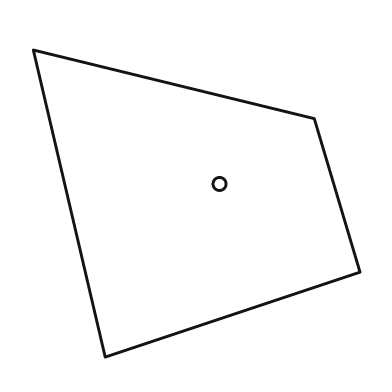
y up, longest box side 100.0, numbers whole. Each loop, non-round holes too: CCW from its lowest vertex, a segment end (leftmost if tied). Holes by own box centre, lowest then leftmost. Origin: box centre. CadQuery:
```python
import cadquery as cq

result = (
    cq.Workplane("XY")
    .moveTo(-28.0, -47.0)
    .lineTo(50.0, -21.0)
    .lineTo(36.0, 26.0)
    .lineTo(-50.0, 47.0)
    .close()
    .moveTo(7.0, 6.0)
    .circle(2.0)
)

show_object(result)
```